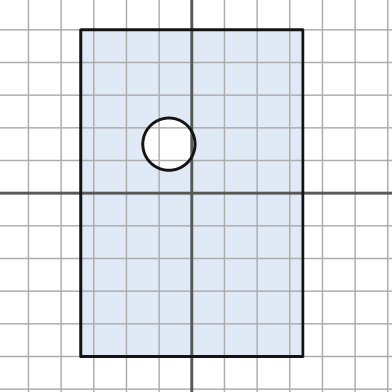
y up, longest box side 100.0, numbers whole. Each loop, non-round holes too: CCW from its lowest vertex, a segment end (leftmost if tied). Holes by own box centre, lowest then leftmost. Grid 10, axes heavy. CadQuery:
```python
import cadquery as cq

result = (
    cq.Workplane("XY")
    .moveTo(-34.0, -50.0)
    .lineTo(34.0, -50.0)
    .lineTo(34.0, 50.0)
    .lineTo(-34.0, 50.0)
    .close()
    .moveTo(-7.0, 15.0)
    .circle(8.0)
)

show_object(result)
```